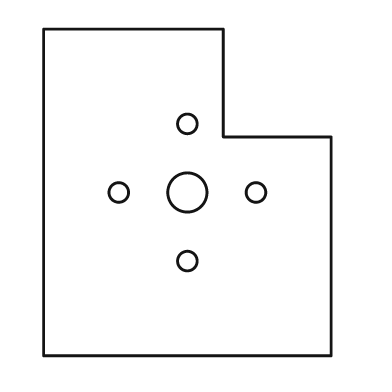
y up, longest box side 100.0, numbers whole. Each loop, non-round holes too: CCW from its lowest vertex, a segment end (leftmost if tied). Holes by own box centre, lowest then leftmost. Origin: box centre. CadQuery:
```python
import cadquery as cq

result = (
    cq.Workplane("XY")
    .moveTo(-44.0, -50.0)
    .lineTo(44.0, -50.0)
    .lineTo(44.0, 17.0)
    .lineTo(11.0, 17.0)
    .lineTo(11.0, 50.0)
    .lineTo(-44.0, 50.0)
    .close()
    .moveTo(0.0, -21.0)
    .circle(3.0)
    .moveTo(-21.0, 0.0)
    .circle(3.0)
    .moveTo(0.0, 0.0)
    .circle(6.0)
    .moveTo(21.0, 0.0)
    .circle(3.0)
    .moveTo(0.0, 21.0)
    .circle(3.0)
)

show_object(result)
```